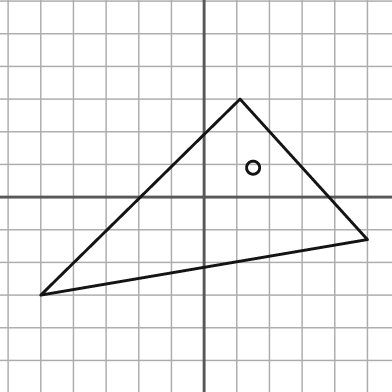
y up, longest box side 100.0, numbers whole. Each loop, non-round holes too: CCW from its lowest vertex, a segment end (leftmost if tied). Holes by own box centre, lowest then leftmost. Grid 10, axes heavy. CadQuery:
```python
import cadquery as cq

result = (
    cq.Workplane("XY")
    .moveTo(-50.0, -30.0)
    .lineTo(50.0, -13.0)
    .lineTo(11.0, 30.0)
    .close()
    .moveTo(15.0, 9.0)
    .circle(2.0)
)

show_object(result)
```